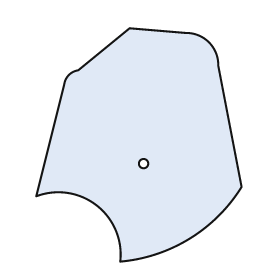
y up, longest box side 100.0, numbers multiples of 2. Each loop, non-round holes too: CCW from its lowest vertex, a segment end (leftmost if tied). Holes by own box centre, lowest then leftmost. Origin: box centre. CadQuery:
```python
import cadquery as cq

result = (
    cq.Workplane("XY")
    .moveTo(-8.0, -50.0)
    .threePointArc((22.0, -40.0), (44.0, -18.0))
    .lineTo(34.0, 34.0)
    .threePointArc((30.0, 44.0), (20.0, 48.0))
    .lineTo(-4.0, 50.0)
    .lineTo(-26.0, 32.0)
    .threePointArc((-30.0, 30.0), (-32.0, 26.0))
    .lineTo(-44.0, -22.0)
    .threePointArc((-18.0, -26.0), (-8.0, -50.0))
    .close()
    .moveTo(2.0, -8.0)
    .circle(2.0)
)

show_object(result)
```